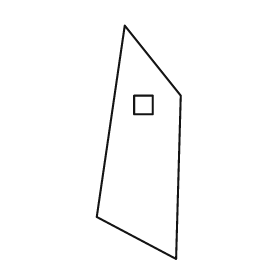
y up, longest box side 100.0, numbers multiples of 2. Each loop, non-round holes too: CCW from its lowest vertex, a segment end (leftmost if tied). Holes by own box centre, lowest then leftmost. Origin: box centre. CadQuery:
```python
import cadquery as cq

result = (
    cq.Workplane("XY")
    .moveTo(16.0, -50.0)
    .lineTo(18.0, 20.0)
    .lineTo(-6.0, 50.0)
    .lineTo(-18.0, -32.0)
    .close()
    .moveTo(-2.0, 12.0)
    .lineTo(6.0, 12.0)
    .lineTo(6.0, 20.0)
    .lineTo(-2.0, 20.0)
    .close()
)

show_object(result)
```